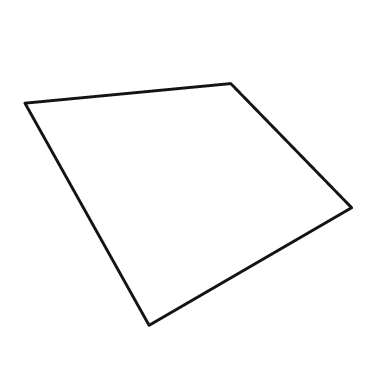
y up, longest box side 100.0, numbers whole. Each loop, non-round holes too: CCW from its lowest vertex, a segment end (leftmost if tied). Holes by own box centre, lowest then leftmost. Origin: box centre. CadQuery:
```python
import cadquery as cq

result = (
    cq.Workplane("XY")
    .moveTo(-12.0, -37.0)
    .lineTo(50.0, -1.0)
    .lineTo(13.0, 37.0)
    .lineTo(-50.0, 31.0)
    .close()
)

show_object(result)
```